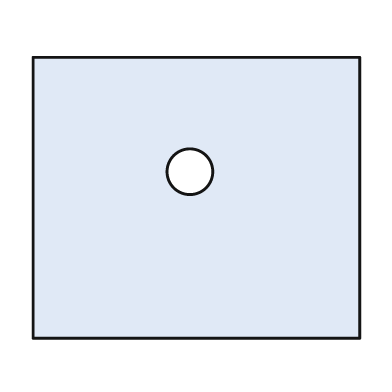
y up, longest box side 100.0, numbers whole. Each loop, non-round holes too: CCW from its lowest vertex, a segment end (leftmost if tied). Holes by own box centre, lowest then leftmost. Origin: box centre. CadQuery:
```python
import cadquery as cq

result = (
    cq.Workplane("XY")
    .moveTo(-50.0, -43.0)
    .lineTo(50.0, -43.0)
    .lineTo(50.0, 43.0)
    .lineTo(-50.0, 43.0)
    .close()
    .moveTo(-2.0, 8.0)
    .circle(7.0)
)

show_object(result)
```